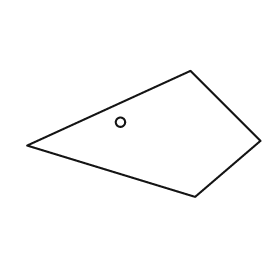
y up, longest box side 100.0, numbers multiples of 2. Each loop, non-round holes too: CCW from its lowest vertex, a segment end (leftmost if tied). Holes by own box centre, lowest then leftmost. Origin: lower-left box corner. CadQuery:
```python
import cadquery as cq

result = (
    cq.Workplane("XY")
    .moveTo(72.0, 0.0)
    .lineTo(100.0, 24.0)
    .lineTo(70.0, 54.0)
    .lineTo(0.0, 22.0)
    .close()
    .moveTo(40.0, 32.0)
    .circle(2.0)
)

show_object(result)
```